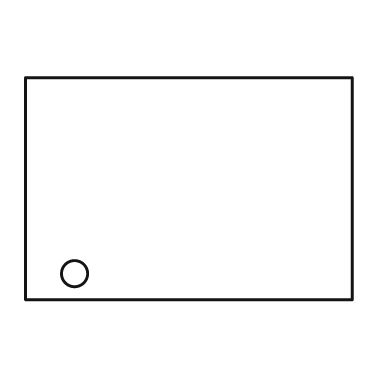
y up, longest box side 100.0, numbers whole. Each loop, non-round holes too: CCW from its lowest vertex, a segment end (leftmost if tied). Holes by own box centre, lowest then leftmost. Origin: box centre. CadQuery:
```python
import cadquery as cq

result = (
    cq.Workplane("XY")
    .moveTo(-50.0, -34.0)
    .lineTo(50.0, -34.0)
    .lineTo(50.0, 34.0)
    .lineTo(-50.0, 34.0)
    .close()
    .moveTo(-35.0, -26.0)
    .circle(4.0)
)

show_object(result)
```